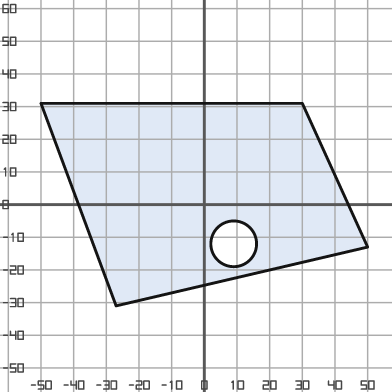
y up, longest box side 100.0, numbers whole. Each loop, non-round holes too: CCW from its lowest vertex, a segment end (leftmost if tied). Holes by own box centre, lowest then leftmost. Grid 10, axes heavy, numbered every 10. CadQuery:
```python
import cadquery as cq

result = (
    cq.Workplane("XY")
    .moveTo(-27.0, -31.0)
    .lineTo(50.0, -13.0)
    .lineTo(30.0, 31.0)
    .lineTo(-50.0, 31.0)
    .close()
    .moveTo(9.0, -12.0)
    .circle(7.0)
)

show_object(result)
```